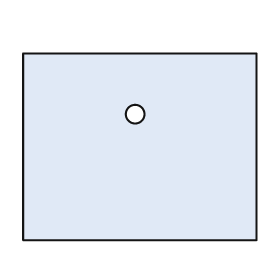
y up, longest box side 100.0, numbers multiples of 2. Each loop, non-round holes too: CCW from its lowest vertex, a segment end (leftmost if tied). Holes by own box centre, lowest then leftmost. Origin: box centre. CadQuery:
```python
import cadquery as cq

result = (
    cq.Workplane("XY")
    .moveTo(-50.0, -40.0)
    .lineTo(50.0, -40.0)
    .lineTo(50.0, 40.0)
    .lineTo(-50.0, 40.0)
    .close()
    .moveTo(-2.0, 14.0)
    .circle(4.0)
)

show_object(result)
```